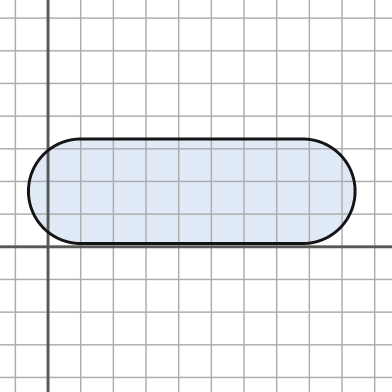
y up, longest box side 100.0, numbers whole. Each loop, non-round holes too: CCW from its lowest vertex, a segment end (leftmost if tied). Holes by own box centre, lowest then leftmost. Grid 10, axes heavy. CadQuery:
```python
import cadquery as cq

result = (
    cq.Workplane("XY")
    .moveTo(10.0, 1.0)
    .lineTo(78.0, 1.0)
    .threePointArc((94.0, 17.0), (78.0, 33.0))
    .lineTo(10.0, 33.0)
    .threePointArc((-6.0, 17.0), (10.0, 1.0))
    .close()
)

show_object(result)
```